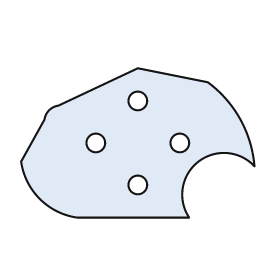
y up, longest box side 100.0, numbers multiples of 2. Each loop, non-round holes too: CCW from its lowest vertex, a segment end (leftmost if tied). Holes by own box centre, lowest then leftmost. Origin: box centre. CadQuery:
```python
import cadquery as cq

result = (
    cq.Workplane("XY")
    .moveTo(-26.0, -32.0)
    .lineTo(22.0, -32.0)
    .threePointArc((26.0, -8.0), (50.0, -10.0))
    .threePointArc((44.0, 10.0), (30.0, 26.0))
    .lineTo(0.0, 32.0)
    .lineTo(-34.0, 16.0)
    .threePointArc((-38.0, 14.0), (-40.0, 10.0))
    .lineTo(-50.0, -8.0)
    .threePointArc((-42.0, -24.0), (-26.0, -32.0))
    .close()
    .moveTo(0.0, -18.0)
    .circle(4.0)
    .moveTo(-18.0, 0.0)
    .circle(4.0)
    .moveTo(18.0, 0.0)
    .circle(4.0)
    .moveTo(0.0, 18.0)
    .circle(4.0)
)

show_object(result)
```